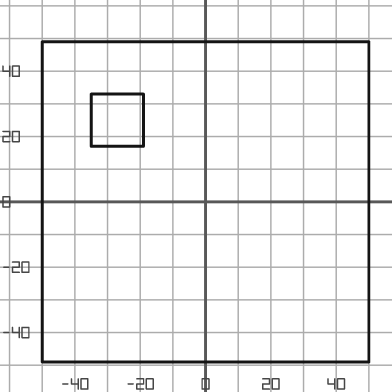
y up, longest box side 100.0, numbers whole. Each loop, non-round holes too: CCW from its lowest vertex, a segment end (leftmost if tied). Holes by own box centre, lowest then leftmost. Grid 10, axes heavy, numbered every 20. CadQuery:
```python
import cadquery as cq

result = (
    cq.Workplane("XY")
    .moveTo(-50.0, -49.0)
    .lineTo(50.0, -49.0)
    .lineTo(50.0, 49.0)
    .lineTo(-50.0, 49.0)
    .close()
    .moveTo(-35.0, 17.0)
    .lineTo(-19.0, 17.0)
    .lineTo(-19.0, 33.0)
    .lineTo(-35.0, 33.0)
    .close()
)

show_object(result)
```